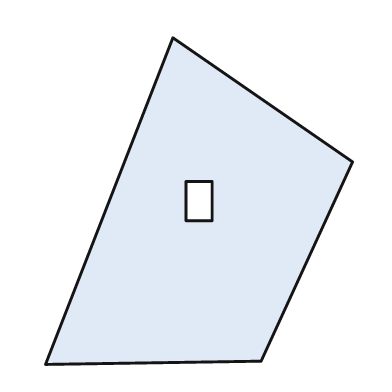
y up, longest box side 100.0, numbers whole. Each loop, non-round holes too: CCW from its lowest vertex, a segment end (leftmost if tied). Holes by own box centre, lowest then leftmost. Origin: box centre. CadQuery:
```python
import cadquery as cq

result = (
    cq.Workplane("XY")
    .moveTo(-47.0, -50.0)
    .lineTo(19.0, -49.0)
    .lineTo(47.0, 12.0)
    .lineTo(-8.0, 50.0)
    .close()
    .moveTo(-4.0, -6.0)
    .lineTo(4.0, -6.0)
    .lineTo(4.0, 6.0)
    .lineTo(-4.0, 6.0)
    .close()
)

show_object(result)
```